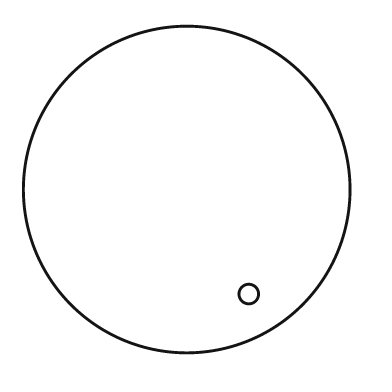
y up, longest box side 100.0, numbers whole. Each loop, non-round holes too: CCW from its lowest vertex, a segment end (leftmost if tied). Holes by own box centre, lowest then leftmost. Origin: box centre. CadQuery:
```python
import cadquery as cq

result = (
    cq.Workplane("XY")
    .moveTo(0.0, 0.0)
    .circle(50.0)
    .moveTo(19.0, -32.0)
    .circle(3.0)
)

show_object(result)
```